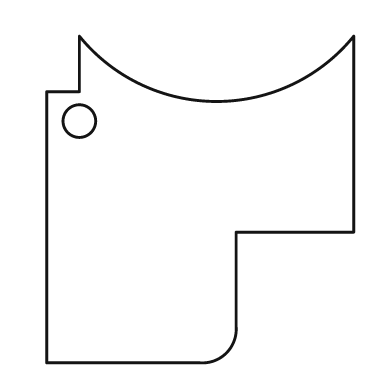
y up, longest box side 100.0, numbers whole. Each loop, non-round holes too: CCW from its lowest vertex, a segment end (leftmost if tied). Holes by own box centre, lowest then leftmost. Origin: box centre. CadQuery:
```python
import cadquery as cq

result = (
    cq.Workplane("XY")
    .moveTo(-47.0, -50.0)
    .lineTo(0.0, -50.0)
    .threePointArc((8.0, -47.0), (11.0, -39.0))
    .lineTo(11.0, -10.0)
    .lineTo(47.0, -10.0)
    .lineTo(47.0, 50.0)
    .threePointArc((5.0, 30.0), (-37.0, 50.0))
    .lineTo(-37.0, 33.0)
    .lineTo(-47.0, 33.0)
    .close()
    .moveTo(-37.0, 24.0)
    .circle(5.0)
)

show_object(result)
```